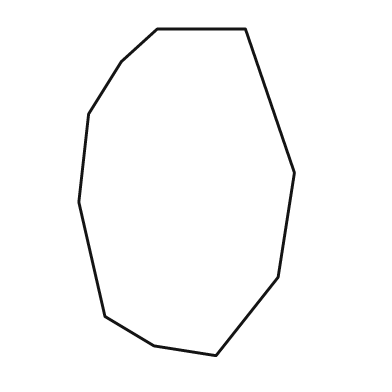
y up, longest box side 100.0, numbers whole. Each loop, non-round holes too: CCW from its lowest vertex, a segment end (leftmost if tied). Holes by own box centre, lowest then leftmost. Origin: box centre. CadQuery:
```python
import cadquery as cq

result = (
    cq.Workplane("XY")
    .moveTo(9.0, -50.0)
    .lineTo(28.0, -26.0)
    .lineTo(33.0, 6.0)
    .lineTo(18.0, 50.0)
    .lineTo(-9.0, 50.0)
    .lineTo(-20.0, 40.0)
    .lineTo(-30.0, 24.0)
    .lineTo(-33.0, -3.0)
    .lineTo(-25.0, -38.0)
    .lineTo(-10.0, -47.0)
    .close()
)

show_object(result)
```